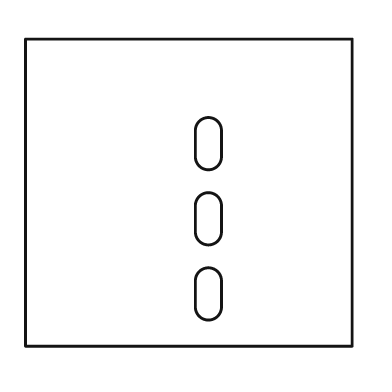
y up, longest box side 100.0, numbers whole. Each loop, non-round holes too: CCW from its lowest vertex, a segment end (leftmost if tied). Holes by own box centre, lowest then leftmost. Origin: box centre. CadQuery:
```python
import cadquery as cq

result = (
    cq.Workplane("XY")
    .moveTo(-50.0, -47.0)
    .lineTo(50.0, -47.0)
    .lineTo(50.0, 47.0)
    .lineTo(-50.0, 47.0)
    .close()
    .moveTo(2.0, -35.0)
    .threePointArc((6.0, -39.0), (10.0, -35.0))
    .lineTo(10.0, -27.0)
    .threePointArc((6.0, -23.0), (2.0, -27.0))
    .close()
    .moveTo(2.0, -12.0)
    .threePointArc((6.0, -16.0), (10.0, -12.0))
    .lineTo(10.0, -4.0)
    .threePointArc((6.0, 0.0), (2.0, -4.0))
    .close()
    .moveTo(2.0, 11.0)
    .threePointArc((6.0, 7.0), (10.0, 11.0))
    .lineTo(10.0, 19.0)
    .threePointArc((6.0, 23.0), (2.0, 19.0))
    .close()
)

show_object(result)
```